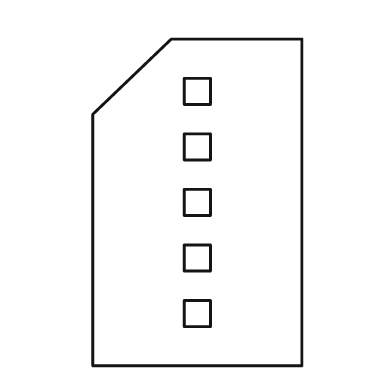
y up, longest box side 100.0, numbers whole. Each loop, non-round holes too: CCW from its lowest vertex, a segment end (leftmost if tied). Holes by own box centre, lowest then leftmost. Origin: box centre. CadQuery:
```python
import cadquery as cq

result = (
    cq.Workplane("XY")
    .moveTo(-32.0, -50.0)
    .lineTo(32.0, -50.0)
    .lineTo(32.0, 50.0)
    .lineTo(-8.0, 50.0)
    .lineTo(-32.0, 27.0)
    .close()
    .moveTo(-4.0, -38.0)
    .lineTo(4.0, -38.0)
    .lineTo(4.0, -30.0)
    .lineTo(-4.0, -30.0)
    .close()
    .moveTo(-4.0, -21.0)
    .lineTo(4.0, -21.0)
    .lineTo(4.0, -13.0)
    .lineTo(-4.0, -13.0)
    .close()
    .moveTo(-4.0, -4.0)
    .lineTo(4.0, -4.0)
    .lineTo(4.0, 4.0)
    .lineTo(-4.0, 4.0)
    .close()
    .moveTo(-4.0, 13.0)
    .lineTo(4.0, 13.0)
    .lineTo(4.0, 21.0)
    .lineTo(-4.0, 21.0)
    .close()
    .moveTo(-4.0, 30.0)
    .lineTo(4.0, 30.0)
    .lineTo(4.0, 38.0)
    .lineTo(-4.0, 38.0)
    .close()
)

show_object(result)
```